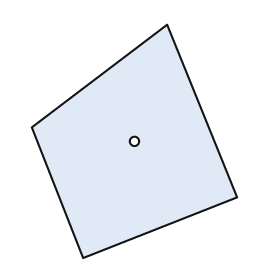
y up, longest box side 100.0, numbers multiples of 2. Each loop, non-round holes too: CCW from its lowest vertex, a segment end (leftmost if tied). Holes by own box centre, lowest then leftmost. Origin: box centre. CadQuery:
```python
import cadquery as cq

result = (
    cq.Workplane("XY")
    .moveTo(-22.0, -50.0)
    .lineTo(44.0, -24.0)
    .lineTo(14.0, 50.0)
    .lineTo(-44.0, 6.0)
    .close()
    .moveTo(0.0, 0.0)
    .circle(2.0)
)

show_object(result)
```